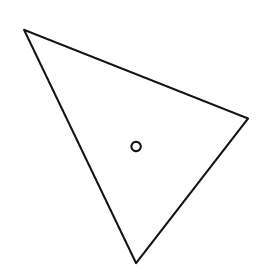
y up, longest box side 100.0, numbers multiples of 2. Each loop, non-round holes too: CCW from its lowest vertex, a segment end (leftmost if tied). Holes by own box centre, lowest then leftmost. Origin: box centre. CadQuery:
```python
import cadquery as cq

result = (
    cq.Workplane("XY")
    .moveTo(0.0, -50.0)
    .lineTo(48.0, 12.0)
    .lineTo(-48.0, 50.0)
    .close()
    .moveTo(0.0, 0.0)
    .circle(2.0)
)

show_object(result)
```